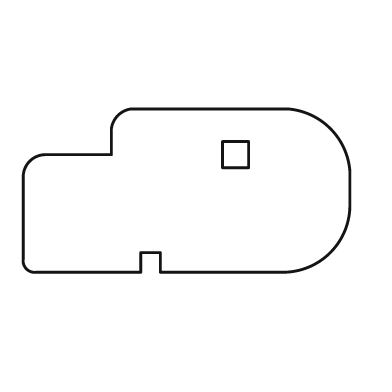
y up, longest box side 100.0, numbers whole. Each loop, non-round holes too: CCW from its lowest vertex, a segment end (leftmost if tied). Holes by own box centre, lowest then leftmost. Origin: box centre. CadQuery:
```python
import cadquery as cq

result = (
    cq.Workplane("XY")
    .moveTo(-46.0, -25.0)
    .lineTo(-14.0, -25.0)
    .lineTo(-14.0, -19.0)
    .lineTo(-8.0, -19.0)
    .lineTo(-8.0, -25.0)
    .lineTo(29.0, -25.0)
    .threePointArc((44.0, -19.0), (50.0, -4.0))
    .lineTo(50.0, 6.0)
    .threePointArc((44.0, 19.0), (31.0, 25.0))
    .lineTo(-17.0, 25.0)
    .threePointArc((-21.0, 23.0), (-23.0, 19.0))
    .lineTo(-23.0, 11.0)
    .lineTo(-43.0, 11.0)
    .threePointArc((-48.0, 9.0), (-50.0, 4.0))
    .lineTo(-50.0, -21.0)
    .threePointArc((-49.0, -24.0), (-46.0, -25.0))
    .close()
    .moveTo(11.0, 7.0)
    .lineTo(19.0, 7.0)
    .lineTo(19.0, 15.0)
    .lineTo(11.0, 15.0)
    .close()
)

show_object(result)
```